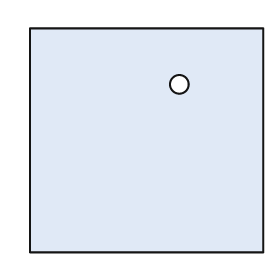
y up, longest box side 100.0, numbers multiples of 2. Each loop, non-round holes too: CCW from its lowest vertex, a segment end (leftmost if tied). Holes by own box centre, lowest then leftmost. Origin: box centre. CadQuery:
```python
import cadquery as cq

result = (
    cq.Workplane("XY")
    .moveTo(-50.0, -48.0)
    .lineTo(50.0, -48.0)
    .lineTo(50.0, 48.0)
    .lineTo(-50.0, 48.0)
    .close()
    .moveTo(14.0, 24.0)
    .circle(4.0)
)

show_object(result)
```